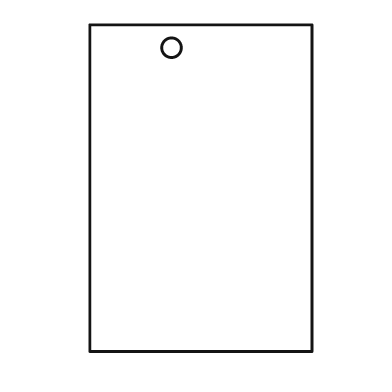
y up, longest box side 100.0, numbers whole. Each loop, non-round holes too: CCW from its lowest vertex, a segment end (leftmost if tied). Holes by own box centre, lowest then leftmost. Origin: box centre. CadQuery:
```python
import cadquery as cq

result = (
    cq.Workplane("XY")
    .moveTo(-34.0, -50.0)
    .lineTo(34.0, -50.0)
    .lineTo(34.0, 50.0)
    .lineTo(-34.0, 50.0)
    .close()
    .moveTo(-9.0, 43.0)
    .circle(3.0)
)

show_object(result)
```